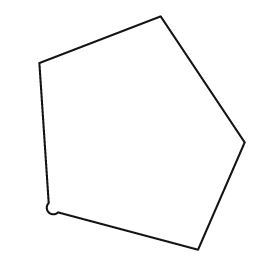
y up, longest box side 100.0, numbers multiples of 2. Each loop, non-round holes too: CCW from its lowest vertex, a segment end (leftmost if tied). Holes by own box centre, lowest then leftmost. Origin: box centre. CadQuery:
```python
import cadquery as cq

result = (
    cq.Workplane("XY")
    .moveTo(24.0, -50.0)
    .lineTo(44.0, -4.0)
    .lineTo(8.0, 50.0)
    .lineTo(-44.0, 30.0)
    .lineTo(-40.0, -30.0)
    .threePointArc((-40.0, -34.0), (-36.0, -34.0))
    .close()
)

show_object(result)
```